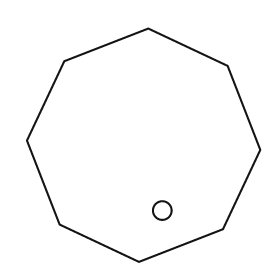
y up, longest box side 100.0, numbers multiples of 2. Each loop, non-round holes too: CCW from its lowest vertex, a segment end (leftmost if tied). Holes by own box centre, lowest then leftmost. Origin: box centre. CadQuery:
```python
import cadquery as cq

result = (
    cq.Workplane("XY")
    .moveTo(-2.0, -50.0)
    .lineTo(34.0, -36.0)
    .lineTo(50.0, -2.0)
    .lineTo(36.0, 34.0)
    .lineTo(2.0, 50.0)
    .lineTo(-34.0, 36.0)
    .lineTo(-50.0, 2.0)
    .lineTo(-36.0, -34.0)
    .close()
    .moveTo(8.0, -28.0)
    .circle(4.0)
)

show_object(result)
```